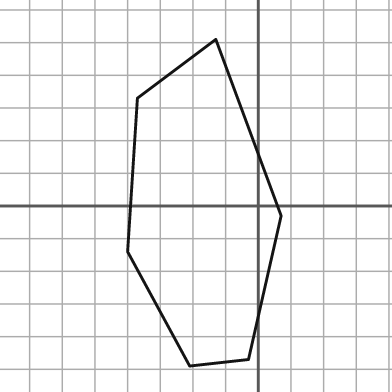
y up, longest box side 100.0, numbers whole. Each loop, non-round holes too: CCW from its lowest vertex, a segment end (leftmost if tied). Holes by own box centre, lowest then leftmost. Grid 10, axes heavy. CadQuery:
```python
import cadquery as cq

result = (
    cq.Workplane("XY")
    .moveTo(-21.0, -49.0)
    .lineTo(-3.0, -47.0)
    .lineTo(7.0, -3.0)
    .lineTo(-13.0, 51.0)
    .lineTo(-37.0, 33.0)
    .lineTo(-40.0, -14.0)
    .close()
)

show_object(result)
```